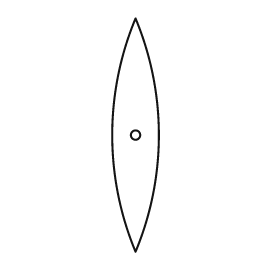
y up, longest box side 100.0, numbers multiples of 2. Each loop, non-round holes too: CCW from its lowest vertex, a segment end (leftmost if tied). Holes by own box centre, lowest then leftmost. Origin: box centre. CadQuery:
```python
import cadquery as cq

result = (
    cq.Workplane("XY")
    .moveTo(0.0, -50.0)
    .threePointArc((10.0, 0.0), (0.0, 50.0))
    .threePointArc((-10.0, 0.0), (0.0, -50.0))
    .close()
    .moveTo(0.0, 0.0)
    .circle(2.0)
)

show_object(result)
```